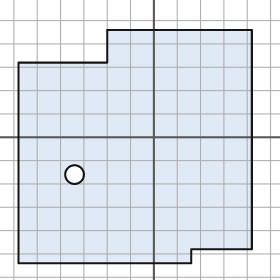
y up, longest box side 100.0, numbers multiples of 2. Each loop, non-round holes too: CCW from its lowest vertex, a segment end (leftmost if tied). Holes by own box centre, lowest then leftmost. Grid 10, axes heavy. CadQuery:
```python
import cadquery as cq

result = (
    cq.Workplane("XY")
    .moveTo(-58.0, -54.0)
    .lineTo(16.0, -54.0)
    .lineTo(16.0, -48.0)
    .lineTo(42.0, -48.0)
    .lineTo(42.0, 46.0)
    .lineTo(-20.0, 46.0)
    .lineTo(-20.0, 32.0)
    .lineTo(-58.0, 32.0)
    .close()
    .moveTo(-34.0, -16.0)
    .circle(4.0)
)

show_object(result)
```